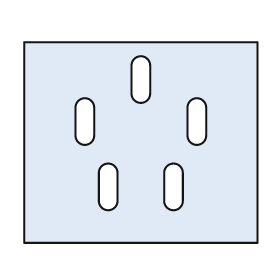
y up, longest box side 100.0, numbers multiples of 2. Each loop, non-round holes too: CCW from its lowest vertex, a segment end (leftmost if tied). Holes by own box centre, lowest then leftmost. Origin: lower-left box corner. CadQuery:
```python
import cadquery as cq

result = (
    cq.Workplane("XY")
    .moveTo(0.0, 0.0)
    .lineTo(100.0, 0.0)
    .lineTo(100.0, 86.0)
    .lineTo(0.0, 86.0)
    .close()
    .moveTo(32.0, 18.0)
    .threePointArc((36.0, 14.0), (40.0, 18.0))
    .lineTo(40.0, 30.0)
    .threePointArc((36.0, 34.0), (32.0, 30.0))
    .close()
    .moveTo(60.0, 18.0)
    .threePointArc((64.0, 14.0), (68.0, 18.0))
    .lineTo(68.0, 30.0)
    .threePointArc((64.0, 34.0), (60.0, 30.0))
    .close()
    .moveTo(22.0, 46.0)
    .threePointArc((26.0, 42.0), (30.0, 46.0))
    .lineTo(30.0, 58.0)
    .threePointArc((26.0, 62.0), (22.0, 58.0))
    .close()
    .moveTo(70.0, 46.0)
    .threePointArc((74.0, 42.0), (78.0, 46.0))
    .lineTo(78.0, 58.0)
    .threePointArc((74.0, 62.0), (70.0, 58.0))
    .close()
    .moveTo(46.0, 64.0)
    .threePointArc((50.0, 60.0), (54.0, 64.0))
    .lineTo(54.0, 76.0)
    .threePointArc((50.0, 80.0), (46.0, 76.0))
    .close()
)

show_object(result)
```